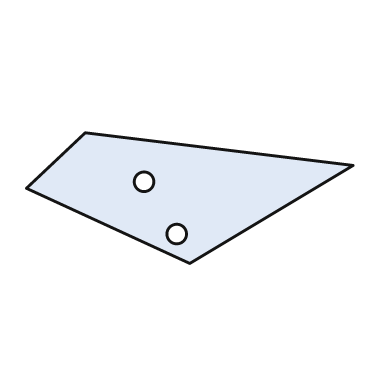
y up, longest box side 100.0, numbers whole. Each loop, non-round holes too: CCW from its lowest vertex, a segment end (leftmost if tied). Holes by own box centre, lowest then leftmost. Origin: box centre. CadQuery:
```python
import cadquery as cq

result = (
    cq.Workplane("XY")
    .moveTo(0.0, -20.0)
    .lineTo(50.0, 10.0)
    .lineTo(-32.0, 20.0)
    .lineTo(-50.0, 3.0)
    .close()
    .moveTo(-4.0, -11.0)
    .circle(3.0)
    .moveTo(-14.0, 5.0)
    .circle(3.0)
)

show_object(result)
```